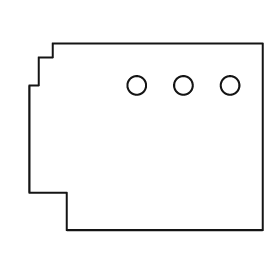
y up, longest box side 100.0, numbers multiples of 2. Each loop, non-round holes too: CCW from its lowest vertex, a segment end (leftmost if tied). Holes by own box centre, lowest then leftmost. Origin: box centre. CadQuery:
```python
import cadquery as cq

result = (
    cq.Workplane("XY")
    .moveTo(-34.0, -40.0)
    .lineTo(50.0, -40.0)
    .lineTo(50.0, 40.0)
    .lineTo(-40.0, 40.0)
    .lineTo(-40.0, 34.0)
    .lineTo(-46.0, 34.0)
    .lineTo(-46.0, 22.0)
    .lineTo(-50.0, 22.0)
    .lineTo(-50.0, -24.0)
    .lineTo(-34.0, -24.0)
    .close()
    .moveTo(-4.0, 22.0)
    .circle(4.0)
    .moveTo(16.0, 22.0)
    .circle(4.0)
    .moveTo(36.0, 22.0)
    .circle(4.0)
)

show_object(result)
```